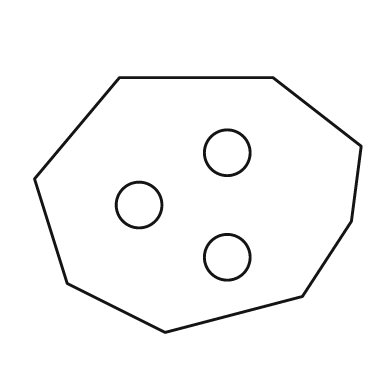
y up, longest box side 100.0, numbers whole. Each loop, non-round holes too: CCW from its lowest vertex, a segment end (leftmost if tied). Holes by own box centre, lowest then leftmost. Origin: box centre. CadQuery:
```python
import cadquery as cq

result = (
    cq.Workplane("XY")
    .moveTo(-10.0, -39.0)
    .lineTo(32.0, -28.0)
    .lineTo(47.0, -5.0)
    .lineTo(50.0, 18.0)
    .lineTo(23.0, 39.0)
    .lineTo(-24.0, 39.0)
    .lineTo(-50.0, 8.0)
    .lineTo(-40.0, -24.0)
    .close()
    .moveTo(9.0, -16.0)
    .circle(7.0)
    .moveTo(-18.0, 0.0)
    .circle(7.0)
    .moveTo(9.0, 16.0)
    .circle(7.0)
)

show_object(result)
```